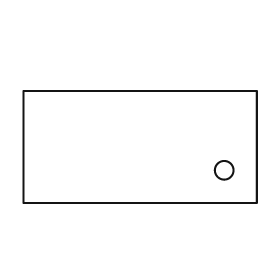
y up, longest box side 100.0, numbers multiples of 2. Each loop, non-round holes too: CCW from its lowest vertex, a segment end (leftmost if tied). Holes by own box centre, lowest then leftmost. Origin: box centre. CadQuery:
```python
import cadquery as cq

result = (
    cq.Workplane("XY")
    .moveTo(-50.0, -24.0)
    .lineTo(50.0, -24.0)
    .lineTo(50.0, 24.0)
    .lineTo(-50.0, 24.0)
    .close()
    .moveTo(36.0, -10.0)
    .circle(4.0)
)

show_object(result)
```